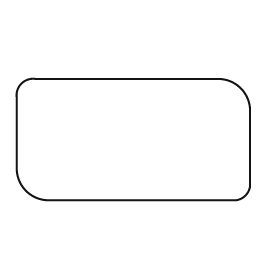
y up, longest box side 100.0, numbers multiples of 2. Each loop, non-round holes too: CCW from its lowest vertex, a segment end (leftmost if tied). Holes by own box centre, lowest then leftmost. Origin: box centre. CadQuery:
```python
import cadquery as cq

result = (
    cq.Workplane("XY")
    .moveTo(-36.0, -26.0)
    .lineTo(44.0, -26.0)
    .threePointArc((48.0, -24.0), (50.0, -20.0))
    .lineTo(50.0, 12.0)
    .threePointArc((46.0, 22.0), (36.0, 26.0))
    .lineTo(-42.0, 26.0)
    .threePointArc((-48.0, 24.0), (-50.0, 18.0))
    .lineTo(-50.0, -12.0)
    .threePointArc((-46.0, -22.0), (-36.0, -26.0))
    .close()
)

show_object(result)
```